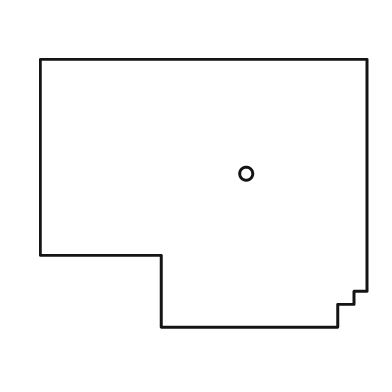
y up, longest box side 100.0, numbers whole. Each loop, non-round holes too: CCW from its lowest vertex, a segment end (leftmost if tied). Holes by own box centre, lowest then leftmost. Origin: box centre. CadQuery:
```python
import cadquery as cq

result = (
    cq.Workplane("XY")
    .moveTo(-13.0, -41.0)
    .lineTo(41.0, -41.0)
    .lineTo(41.0, -34.0)
    .lineTo(46.0, -34.0)
    .lineTo(46.0, -30.0)
    .lineTo(50.0, -30.0)
    .lineTo(50.0, 41.0)
    .lineTo(-50.0, 41.0)
    .lineTo(-50.0, -19.0)
    .lineTo(-13.0, -19.0)
    .close()
    .moveTo(13.0, 6.0)
    .circle(2.0)
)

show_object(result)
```